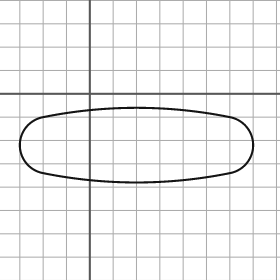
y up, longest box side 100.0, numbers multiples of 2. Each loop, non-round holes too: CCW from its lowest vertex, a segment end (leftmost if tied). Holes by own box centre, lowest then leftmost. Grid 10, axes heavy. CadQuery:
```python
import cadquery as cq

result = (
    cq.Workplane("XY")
    .moveTo(-20.0, -34.0)
    .threePointArc((20.0, -38.0), (60.0, -34.0))
    .threePointArc((70.0, -22.0), (60.0, -10.0))
    .threePointArc((20.0, -6.0), (-20.0, -10.0))
    .threePointArc((-30.0, -22.0), (-20.0, -34.0))
    .close()
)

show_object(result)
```